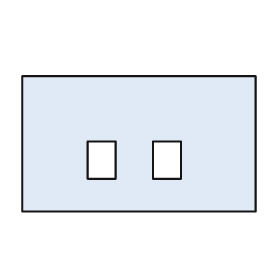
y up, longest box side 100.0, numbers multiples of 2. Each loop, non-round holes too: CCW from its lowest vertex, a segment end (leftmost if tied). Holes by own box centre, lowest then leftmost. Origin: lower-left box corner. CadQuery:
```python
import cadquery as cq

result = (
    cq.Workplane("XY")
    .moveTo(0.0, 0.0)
    .lineTo(100.0, 0.0)
    .lineTo(100.0, 58.0)
    .lineTo(0.0, 58.0)
    .close()
    .moveTo(28.0, 14.0)
    .lineTo(40.0, 14.0)
    .lineTo(40.0, 30.0)
    .lineTo(28.0, 30.0)
    .close()
    .moveTo(56.0, 14.0)
    .lineTo(68.0, 14.0)
    .lineTo(68.0, 30.0)
    .lineTo(56.0, 30.0)
    .close()
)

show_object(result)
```